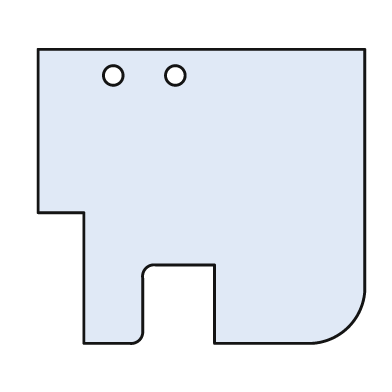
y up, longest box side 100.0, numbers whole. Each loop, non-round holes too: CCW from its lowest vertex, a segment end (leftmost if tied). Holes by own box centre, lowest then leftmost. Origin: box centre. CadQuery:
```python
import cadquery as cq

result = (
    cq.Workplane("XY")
    .moveTo(-36.0, -45.0)
    .lineTo(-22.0, -45.0)
    .threePointArc((-19.0, -44.0), (-18.0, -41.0))
    .lineTo(-18.0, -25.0)
    .threePointArc((-17.0, -22.0), (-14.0, -21.0))
    .lineTo(4.0, -21.0)
    .lineTo(4.0, -45.0)
    .lineTo(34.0, -45.0)
    .threePointArc((45.0, -40.0), (50.0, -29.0))
    .lineTo(50.0, 45.0)
    .lineTo(-50.0, 45.0)
    .lineTo(-50.0, -5.0)
    .lineTo(-36.0, -5.0)
    .close()
    .moveTo(-27.0, 37.0)
    .circle(3.0)
    .moveTo(-8.0, 37.0)
    .circle(3.0)
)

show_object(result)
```